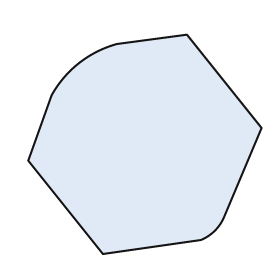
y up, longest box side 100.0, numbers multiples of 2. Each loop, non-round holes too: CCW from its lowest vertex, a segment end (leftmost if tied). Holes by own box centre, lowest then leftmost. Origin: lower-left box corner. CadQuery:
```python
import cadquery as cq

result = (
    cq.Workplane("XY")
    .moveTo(32.0, 0.0)
    .lineTo(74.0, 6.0)
    .threePointArc((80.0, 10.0), (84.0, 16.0))
    .lineTo(100.0, 54.0)
    .lineTo(68.0, 94.0)
    .lineTo(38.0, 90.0)
    .threePointArc((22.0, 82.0), (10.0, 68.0))
    .lineTo(0.0, 40.0)
    .close()
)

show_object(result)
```